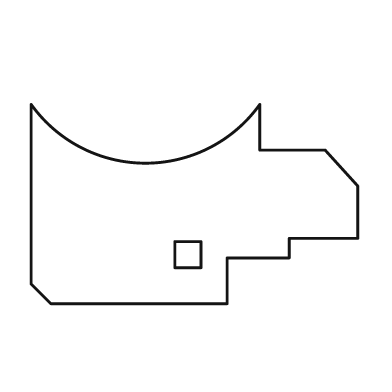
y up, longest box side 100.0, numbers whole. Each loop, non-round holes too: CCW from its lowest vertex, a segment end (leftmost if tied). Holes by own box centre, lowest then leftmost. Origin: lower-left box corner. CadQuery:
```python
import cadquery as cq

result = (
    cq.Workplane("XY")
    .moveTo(6.0, 0.0)
    .lineTo(60.0, 0.0)
    .lineTo(60.0, 14.0)
    .lineTo(79.0, 14.0)
    .lineTo(79.0, 20.0)
    .lineTo(100.0, 20.0)
    .lineTo(100.0, 36.0)
    .lineTo(90.0, 47.0)
    .lineTo(70.0, 47.0)
    .lineTo(70.0, 61.0)
    .threePointArc((35.0, 43.0), (0.0, 61.0))
    .lineTo(0.0, 6.0)
    .close()
    .moveTo(44.0, 11.0)
    .lineTo(52.0, 11.0)
    .lineTo(52.0, 19.0)
    .lineTo(44.0, 19.0)
    .close()
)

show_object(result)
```